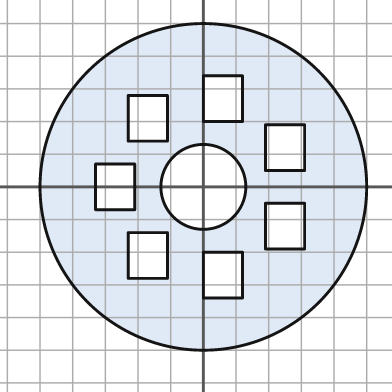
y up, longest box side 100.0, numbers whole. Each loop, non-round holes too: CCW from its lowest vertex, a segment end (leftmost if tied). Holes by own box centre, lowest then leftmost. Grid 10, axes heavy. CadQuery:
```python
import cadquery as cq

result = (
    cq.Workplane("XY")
    .moveTo(0.0, 0.0)
    .circle(50.0)
    .moveTo(0.0, -34.0)
    .lineTo(12.0, -34.0)
    .lineTo(12.0, -20.0)
    .lineTo(0.0, -20.0)
    .close()
    .moveTo(-23.0, -28.0)
    .lineTo(-11.0, -28.0)
    .lineTo(-11.0, -14.0)
    .lineTo(-23.0, -14.0)
    .close()
    .moveTo(19.0, -19.0)
    .lineTo(31.0, -19.0)
    .lineTo(31.0, -5.0)
    .lineTo(19.0, -5.0)
    .close()
    .moveTo(-33.0, -7.0)
    .lineTo(-21.0, -7.0)
    .lineTo(-21.0, 7.0)
    .lineTo(-33.0, 7.0)
    .close()
    .moveTo(0.0, 0.0)
    .circle(13.0)
    .moveTo(19.0, 5.0)
    .lineTo(31.0, 5.0)
    .lineTo(31.0, 19.0)
    .lineTo(19.0, 19.0)
    .close()
    .moveTo(-23.0, 14.0)
    .lineTo(-11.0, 14.0)
    .lineTo(-11.0, 28.0)
    .lineTo(-23.0, 28.0)
    .close()
    .moveTo(0.0, 20.0)
    .lineTo(12.0, 20.0)
    .lineTo(12.0, 34.0)
    .lineTo(0.0, 34.0)
    .close()
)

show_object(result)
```